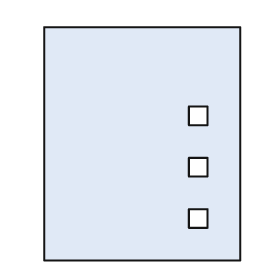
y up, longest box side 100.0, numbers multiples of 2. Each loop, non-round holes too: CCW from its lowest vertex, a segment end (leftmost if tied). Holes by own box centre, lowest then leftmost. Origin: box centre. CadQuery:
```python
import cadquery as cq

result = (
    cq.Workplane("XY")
    .moveTo(-42.0, -50.0)
    .lineTo(42.0, -50.0)
    .lineTo(42.0, 50.0)
    .lineTo(-42.0, 50.0)
    .close()
    .moveTo(20.0, -36.0)
    .lineTo(28.0, -36.0)
    .lineTo(28.0, -28.0)
    .lineTo(20.0, -28.0)
    .close()
    .moveTo(20.0, -14.0)
    .lineTo(28.0, -14.0)
    .lineTo(28.0, -6.0)
    .lineTo(20.0, -6.0)
    .close()
    .moveTo(20.0, 8.0)
    .lineTo(28.0, 8.0)
    .lineTo(28.0, 16.0)
    .lineTo(20.0, 16.0)
    .close()
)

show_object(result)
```